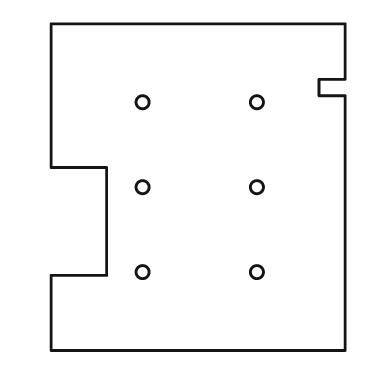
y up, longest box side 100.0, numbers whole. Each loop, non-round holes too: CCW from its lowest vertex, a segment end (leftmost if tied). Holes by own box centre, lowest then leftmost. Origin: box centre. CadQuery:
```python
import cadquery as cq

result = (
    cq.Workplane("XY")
    .moveTo(-45.0, -50.0)
    .lineTo(45.0, -50.0)
    .lineTo(45.0, 28.0)
    .lineTo(37.0, 28.0)
    .lineTo(37.0, 33.0)
    .lineTo(45.0, 33.0)
    .lineTo(45.0, 50.0)
    .lineTo(-45.0, 50.0)
    .lineTo(-45.0, 6.0)
    .lineTo(-28.0, 6.0)
    .lineTo(-28.0, -27.0)
    .lineTo(-45.0, -27.0)
    .close()
    .moveTo(-17.0, -26.0)
    .circle(2.0)
    .moveTo(18.0, -26.0)
    .circle(2.0)
    .moveTo(-17.0, 0.0)
    .circle(2.0)
    .moveTo(18.0, 0.0)
    .circle(2.0)
    .moveTo(-17.0, 26.0)
    .circle(2.0)
    .moveTo(18.0, 26.0)
    .circle(2.0)
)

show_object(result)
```